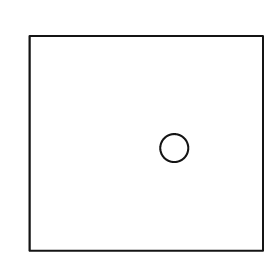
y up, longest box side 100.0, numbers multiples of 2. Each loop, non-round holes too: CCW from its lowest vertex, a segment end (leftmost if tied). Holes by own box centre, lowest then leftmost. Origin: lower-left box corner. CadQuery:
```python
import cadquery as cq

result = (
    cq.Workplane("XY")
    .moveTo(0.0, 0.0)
    .lineTo(100.0, 0.0)
    .lineTo(100.0, 92.0)
    .lineTo(0.0, 92.0)
    .close()
    .moveTo(62.0, 44.0)
    .circle(6.0)
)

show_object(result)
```